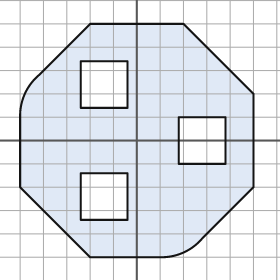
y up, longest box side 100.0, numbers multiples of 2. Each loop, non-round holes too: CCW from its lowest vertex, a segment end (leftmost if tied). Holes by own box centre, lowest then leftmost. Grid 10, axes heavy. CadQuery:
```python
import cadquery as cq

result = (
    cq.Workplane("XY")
    .moveTo(-20.0, -50.0)
    .lineTo(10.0, -50.0)
    .threePointArc((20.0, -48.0), (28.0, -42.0))
    .lineTo(50.0, -20.0)
    .lineTo(50.0, 20.0)
    .lineTo(20.0, 50.0)
    .lineTo(-20.0, 50.0)
    .lineTo(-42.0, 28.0)
    .threePointArc((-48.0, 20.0), (-50.0, 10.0))
    .lineTo(-50.0, -20.0)
    .close()
    .moveTo(-24.0, -34.0)
    .lineTo(-4.0, -34.0)
    .lineTo(-4.0, -14.0)
    .lineTo(-24.0, -14.0)
    .close()
    .moveTo(18.0, -10.0)
    .lineTo(38.0, -10.0)
    .lineTo(38.0, 10.0)
    .lineTo(18.0, 10.0)
    .close()
    .moveTo(-24.0, 14.0)
    .lineTo(-4.0, 14.0)
    .lineTo(-4.0, 34.0)
    .lineTo(-24.0, 34.0)
    .close()
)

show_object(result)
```